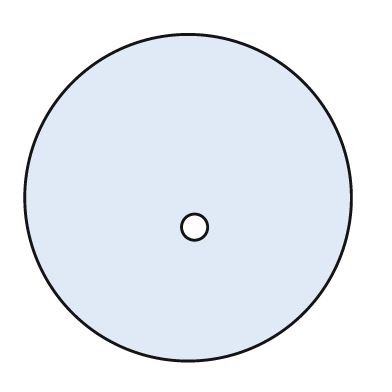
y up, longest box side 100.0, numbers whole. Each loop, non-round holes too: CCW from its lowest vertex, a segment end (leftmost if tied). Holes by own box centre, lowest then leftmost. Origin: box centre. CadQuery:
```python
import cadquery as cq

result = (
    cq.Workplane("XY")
    .moveTo(0.0, 0.0)
    .circle(50.0)
    .moveTo(2.0, -9.0)
    .circle(4.0)
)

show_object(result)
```